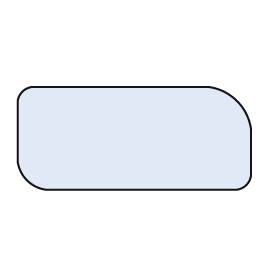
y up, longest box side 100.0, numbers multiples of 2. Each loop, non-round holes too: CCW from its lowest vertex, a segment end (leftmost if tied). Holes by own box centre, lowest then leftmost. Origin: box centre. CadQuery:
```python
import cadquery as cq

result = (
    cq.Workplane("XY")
    .moveTo(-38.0, -22.0)
    .lineTo(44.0, -22.0)
    .threePointArc((48.0, -20.0), (50.0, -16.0))
    .lineTo(50.0, 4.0)
    .threePointArc((44.0, 16.0), (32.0, 22.0))
    .lineTo(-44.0, 22.0)
    .threePointArc((-48.0, 20.0), (-50.0, 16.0))
    .lineTo(-50.0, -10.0)
    .threePointArc((-46.0, -18.0), (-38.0, -22.0))
    .close()
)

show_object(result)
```